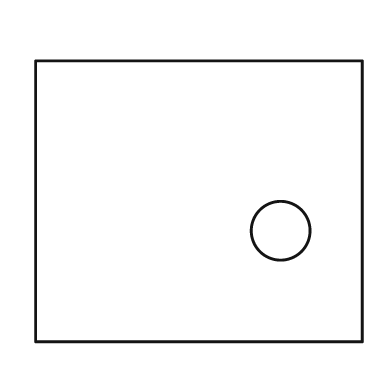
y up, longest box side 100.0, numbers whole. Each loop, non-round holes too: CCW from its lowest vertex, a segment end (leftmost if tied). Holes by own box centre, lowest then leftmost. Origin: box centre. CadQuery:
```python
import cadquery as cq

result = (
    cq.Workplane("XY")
    .moveTo(-50.0, -43.0)
    .lineTo(50.0, -43.0)
    .lineTo(50.0, 43.0)
    .lineTo(-50.0, 43.0)
    .close()
    .moveTo(25.0, -9.0)
    .circle(9.0)
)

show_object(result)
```